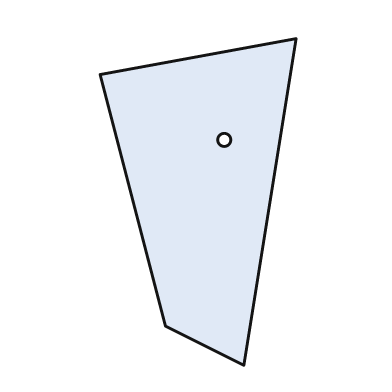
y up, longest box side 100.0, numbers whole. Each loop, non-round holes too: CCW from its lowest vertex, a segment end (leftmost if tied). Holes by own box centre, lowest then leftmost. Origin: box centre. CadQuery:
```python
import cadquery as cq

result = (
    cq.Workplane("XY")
    .moveTo(14.0, -50.0)
    .lineTo(30.0, 50.0)
    .lineTo(-30.0, 39.0)
    .lineTo(-10.0, -38.0)
    .close()
    .moveTo(8.0, 19.0)
    .circle(2.0)
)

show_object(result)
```